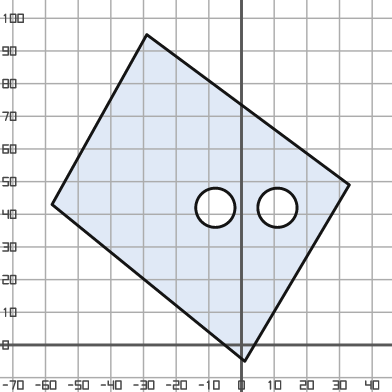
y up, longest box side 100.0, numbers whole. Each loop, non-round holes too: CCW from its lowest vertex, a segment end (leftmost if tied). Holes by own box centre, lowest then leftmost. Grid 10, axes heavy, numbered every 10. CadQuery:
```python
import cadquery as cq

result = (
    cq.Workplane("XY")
    .moveTo(1.0, -5.0)
    .lineTo(33.0, 49.0)
    .lineTo(-29.0, 95.0)
    .lineTo(-58.0, 43.0)
    .close()
    .moveTo(-8.0, 42.0)
    .circle(6.0)
    .moveTo(11.0, 42.0)
    .circle(6.0)
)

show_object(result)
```